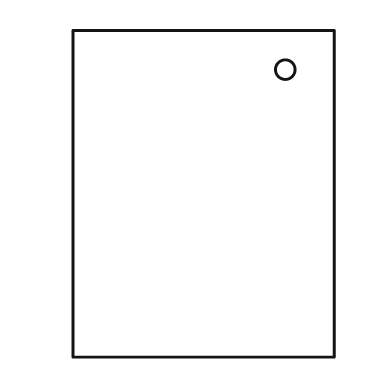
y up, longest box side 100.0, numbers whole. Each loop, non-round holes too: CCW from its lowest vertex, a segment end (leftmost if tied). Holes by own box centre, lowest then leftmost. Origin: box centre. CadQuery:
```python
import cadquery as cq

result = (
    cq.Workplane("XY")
    .moveTo(-40.0, -50.0)
    .lineTo(40.0, -50.0)
    .lineTo(40.0, 50.0)
    .lineTo(-40.0, 50.0)
    .close()
    .moveTo(25.0, 38.0)
    .circle(3.0)
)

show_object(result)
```